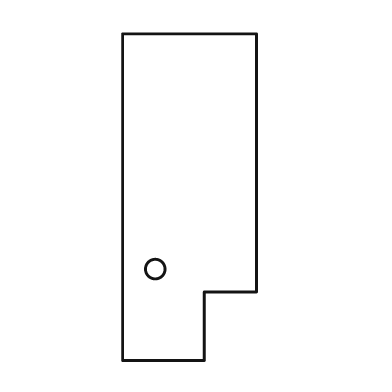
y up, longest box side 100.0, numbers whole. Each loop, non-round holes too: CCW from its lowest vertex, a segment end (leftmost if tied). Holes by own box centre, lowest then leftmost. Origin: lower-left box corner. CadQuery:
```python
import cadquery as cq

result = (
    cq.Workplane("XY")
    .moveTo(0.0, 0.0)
    .lineTo(25.0, 0.0)
    .lineTo(25.0, 21.0)
    .lineTo(41.0, 21.0)
    .lineTo(41.0, 100.0)
    .lineTo(0.0, 100.0)
    .close()
    .moveTo(10.0, 28.0)
    .circle(3.0)
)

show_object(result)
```